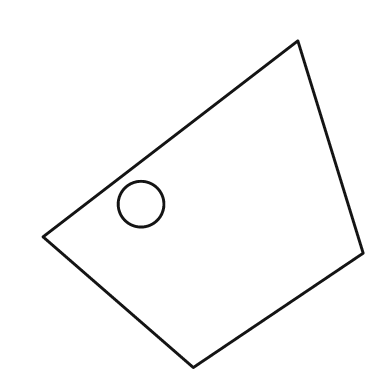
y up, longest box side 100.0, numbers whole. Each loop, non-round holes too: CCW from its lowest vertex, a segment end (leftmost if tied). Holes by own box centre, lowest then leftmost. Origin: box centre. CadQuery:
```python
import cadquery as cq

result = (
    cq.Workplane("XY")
    .moveTo(-3.0, -50.0)
    .lineTo(49.0, -15.0)
    .lineTo(29.0, 50.0)
    .lineTo(-49.0, -10.0)
    .close()
    .moveTo(-19.0, 0.0)
    .circle(7.0)
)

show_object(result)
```